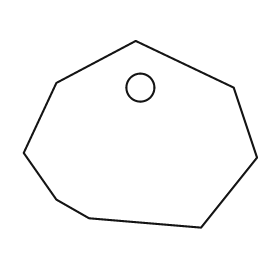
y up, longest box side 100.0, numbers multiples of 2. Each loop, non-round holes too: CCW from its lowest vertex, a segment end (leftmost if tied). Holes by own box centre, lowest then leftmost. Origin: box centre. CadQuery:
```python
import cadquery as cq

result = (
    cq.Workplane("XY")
    .moveTo(26.0, -40.0)
    .lineTo(50.0, -10.0)
    .lineTo(40.0, 20.0)
    .lineTo(-2.0, 40.0)
    .lineTo(-36.0, 22.0)
    .lineTo(-50.0, -8.0)
    .lineTo(-36.0, -28.0)
    .lineTo(-22.0, -36.0)
    .close()
    .moveTo(0.0, 20.0)
    .circle(6.0)
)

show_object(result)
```